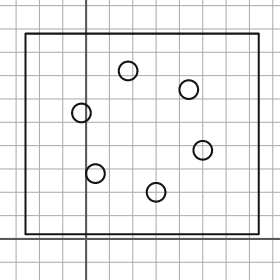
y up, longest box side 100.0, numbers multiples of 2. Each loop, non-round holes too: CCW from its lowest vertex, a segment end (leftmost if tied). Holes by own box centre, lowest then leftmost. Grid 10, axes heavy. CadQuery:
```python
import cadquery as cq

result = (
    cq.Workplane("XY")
    .moveTo(-26.0, 2.0)
    .lineTo(74.0, 2.0)
    .lineTo(74.0, 88.0)
    .lineTo(-26.0, 88.0)
    .close()
    .moveTo(30.0, 20.0)
    .circle(4.0)
    .moveTo(4.0, 28.0)
    .circle(4.0)
    .moveTo(50.0, 38.0)
    .circle(4.0)
    .moveTo(-2.0, 54.0)
    .circle(4.0)
    .moveTo(44.0, 64.0)
    .circle(4.0)
    .moveTo(18.0, 72.0)
    .circle(4.0)
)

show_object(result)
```